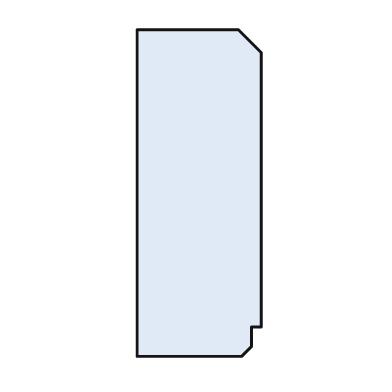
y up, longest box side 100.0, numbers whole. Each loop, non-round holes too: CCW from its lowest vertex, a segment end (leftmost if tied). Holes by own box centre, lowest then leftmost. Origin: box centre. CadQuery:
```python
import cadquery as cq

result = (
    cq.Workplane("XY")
    .moveTo(-19.0, -50.0)
    .lineTo(13.0, -50.0)
    .lineTo(16.0, -47.0)
    .lineTo(16.0, -41.0)
    .lineTo(19.0, -41.0)
    .lineTo(19.0, 43.0)
    .lineTo(12.0, 50.0)
    .lineTo(-19.0, 50.0)
    .close()
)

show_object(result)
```